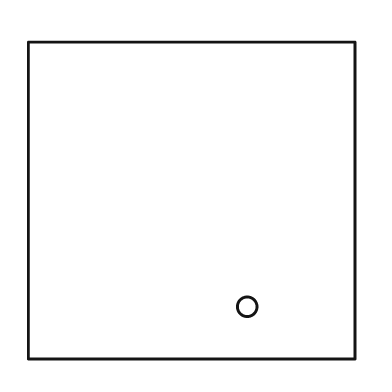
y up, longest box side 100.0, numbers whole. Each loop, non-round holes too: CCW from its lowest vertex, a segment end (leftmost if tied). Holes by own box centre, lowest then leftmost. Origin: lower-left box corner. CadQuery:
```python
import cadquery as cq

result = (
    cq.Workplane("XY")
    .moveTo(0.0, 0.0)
    .lineTo(100.0, 0.0)
    .lineTo(100.0, 97.0)
    .lineTo(0.0, 97.0)
    .close()
    .moveTo(67.0, 16.0)
    .circle(3.0)
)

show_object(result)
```